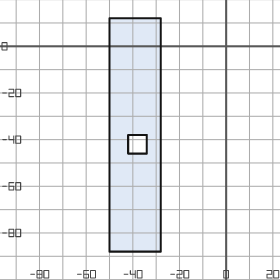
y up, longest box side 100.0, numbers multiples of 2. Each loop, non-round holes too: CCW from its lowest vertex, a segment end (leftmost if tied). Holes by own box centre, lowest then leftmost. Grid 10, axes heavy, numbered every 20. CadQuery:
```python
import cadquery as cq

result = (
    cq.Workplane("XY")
    .moveTo(-50.0, -88.0)
    .lineTo(-28.0, -88.0)
    .lineTo(-28.0, 12.0)
    .lineTo(-50.0, 12.0)
    .close()
    .moveTo(-42.0, -46.0)
    .lineTo(-34.0, -46.0)
    .lineTo(-34.0, -38.0)
    .lineTo(-42.0, -38.0)
    .close()
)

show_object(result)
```